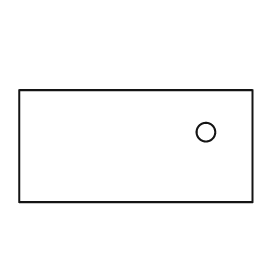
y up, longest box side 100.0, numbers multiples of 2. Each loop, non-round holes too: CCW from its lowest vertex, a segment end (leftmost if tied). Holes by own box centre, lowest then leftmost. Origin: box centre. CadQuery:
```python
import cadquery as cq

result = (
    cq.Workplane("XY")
    .moveTo(-50.0, -24.0)
    .lineTo(50.0, -24.0)
    .lineTo(50.0, 24.0)
    .lineTo(-50.0, 24.0)
    .close()
    .moveTo(30.0, 6.0)
    .circle(4.0)
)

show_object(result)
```